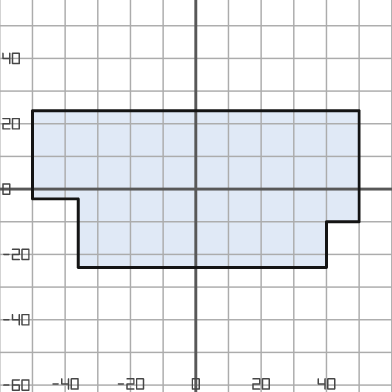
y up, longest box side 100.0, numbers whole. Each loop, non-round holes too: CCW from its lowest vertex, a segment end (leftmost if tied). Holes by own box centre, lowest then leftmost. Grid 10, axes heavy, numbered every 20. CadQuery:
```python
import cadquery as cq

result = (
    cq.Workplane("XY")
    .moveTo(-36.0, -24.0)
    .lineTo(40.0, -24.0)
    .lineTo(40.0, -10.0)
    .lineTo(50.0, -10.0)
    .lineTo(50.0, 24.0)
    .lineTo(-50.0, 24.0)
    .lineTo(-50.0, -3.0)
    .lineTo(-36.0, -3.0)
    .close()
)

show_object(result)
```